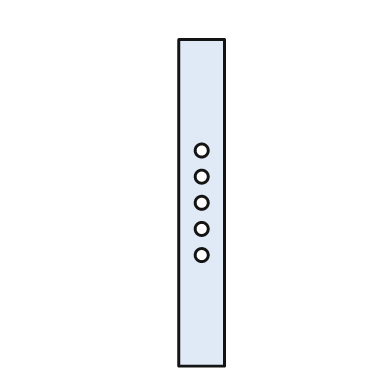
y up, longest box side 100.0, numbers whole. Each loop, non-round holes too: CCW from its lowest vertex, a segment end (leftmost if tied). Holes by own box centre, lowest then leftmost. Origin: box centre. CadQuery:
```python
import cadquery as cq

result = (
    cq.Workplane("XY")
    .moveTo(-7.0, -50.0)
    .lineTo(7.0, -50.0)
    .lineTo(7.0, 50.0)
    .lineTo(-7.0, 50.0)
    .close()
    .moveTo(0.0, -16.0)
    .circle(2.0)
    .moveTo(0.0, -8.0)
    .circle(2.0)
    .moveTo(0.0, 0.0)
    .circle(2.0)
    .moveTo(0.0, 8.0)
    .circle(2.0)
    .moveTo(0.0, 16.0)
    .circle(2.0)
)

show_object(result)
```